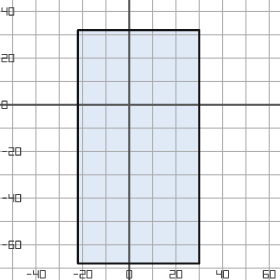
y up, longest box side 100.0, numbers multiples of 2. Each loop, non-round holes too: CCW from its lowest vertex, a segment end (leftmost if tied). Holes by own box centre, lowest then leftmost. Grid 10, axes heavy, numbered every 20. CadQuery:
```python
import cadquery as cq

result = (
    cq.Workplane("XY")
    .moveTo(-22.0, -68.0)
    .lineTo(30.0, -68.0)
    .lineTo(30.0, 32.0)
    .lineTo(-22.0, 32.0)
    .close()
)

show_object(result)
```